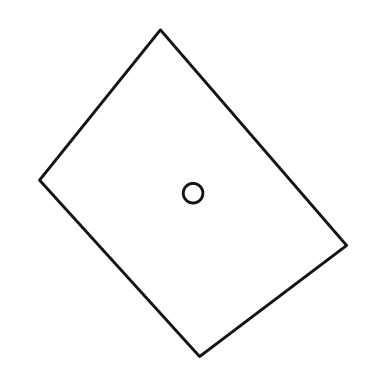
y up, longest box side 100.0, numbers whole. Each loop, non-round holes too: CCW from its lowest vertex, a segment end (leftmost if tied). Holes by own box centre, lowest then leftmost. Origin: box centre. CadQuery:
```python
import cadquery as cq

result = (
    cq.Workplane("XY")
    .moveTo(2.0, -50.0)
    .lineTo(47.0, -16.0)
    .lineTo(-10.0, 50.0)
    .lineTo(-47.0, 4.0)
    .close()
    .moveTo(0.0, 0.0)
    .circle(3.0)
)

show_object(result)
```